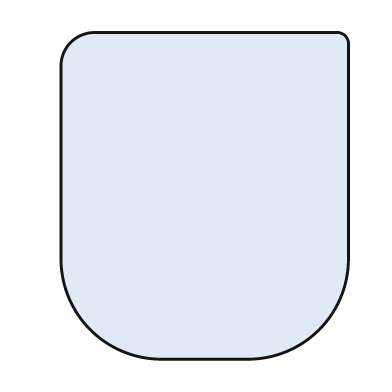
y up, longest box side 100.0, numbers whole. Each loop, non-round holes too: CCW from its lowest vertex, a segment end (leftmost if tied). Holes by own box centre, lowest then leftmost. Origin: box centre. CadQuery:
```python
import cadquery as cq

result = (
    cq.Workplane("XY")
    .moveTo(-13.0, -50.0)
    .lineTo(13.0, -50.0)
    .threePointArc((35.0, -41.0), (44.0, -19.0))
    .lineTo(44.0, 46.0)
    .threePointArc((43.0, 49.0), (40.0, 50.0))
    .lineTo(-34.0, 50.0)
    .threePointArc((-41.0, 47.0), (-44.0, 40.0))
    .lineTo(-44.0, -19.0)
    .threePointArc((-35.0, -41.0), (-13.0, -50.0))
    .close()
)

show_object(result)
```